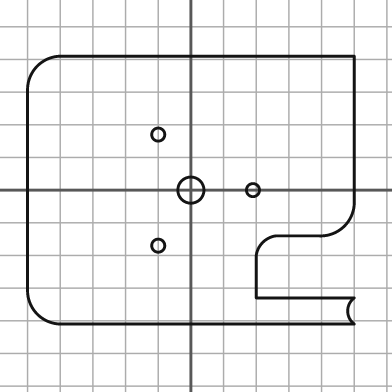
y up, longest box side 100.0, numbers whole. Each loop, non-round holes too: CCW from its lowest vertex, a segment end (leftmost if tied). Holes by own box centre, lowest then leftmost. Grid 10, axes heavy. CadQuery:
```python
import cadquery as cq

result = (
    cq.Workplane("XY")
    .moveTo(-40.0, -41.0)
    .lineTo(50.0, -41.0)
    .threePointArc((48.0, -37.0), (50.0, -33.0))
    .lineTo(20.0, -33.0)
    .lineTo(20.0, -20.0)
    .threePointArc((22.0, -16.0), (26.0, -14.0))
    .lineTo(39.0, -14.0)
    .threePointArc((47.0, -11.0), (50.0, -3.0))
    .lineTo(50.0, 41.0)
    .lineTo(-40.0, 41.0)
    .threePointArc((-47.0, 38.0), (-50.0, 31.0))
    .lineTo(-50.0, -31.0)
    .threePointArc((-47.0, -38.0), (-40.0, -41.0))
    .close()
    .moveTo(-10.0, -17.0)
    .circle(2.0)
    .moveTo(0.0, 0.0)
    .circle(4.0)
    .moveTo(19.0, 0.0)
    .circle(2.0)
    .moveTo(-10.0, 17.0)
    .circle(2.0)
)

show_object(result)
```